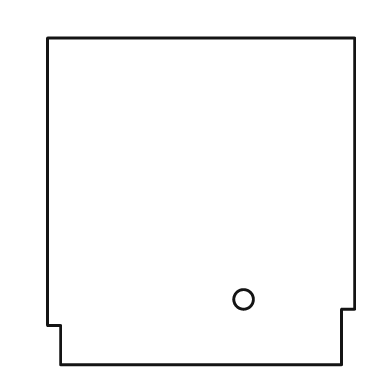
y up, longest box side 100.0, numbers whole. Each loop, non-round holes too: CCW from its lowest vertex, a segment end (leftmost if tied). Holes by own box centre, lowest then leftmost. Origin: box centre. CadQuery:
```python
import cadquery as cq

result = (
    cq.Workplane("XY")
    .moveTo(-43.0, -50.0)
    .lineTo(43.0, -50.0)
    .lineTo(43.0, -33.0)
    .lineTo(47.0, -33.0)
    .lineTo(47.0, 50.0)
    .lineTo(-47.0, 50.0)
    .lineTo(-47.0, -38.0)
    .lineTo(-43.0, -38.0)
    .close()
    .moveTo(13.0, -30.0)
    .circle(3.0)
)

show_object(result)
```